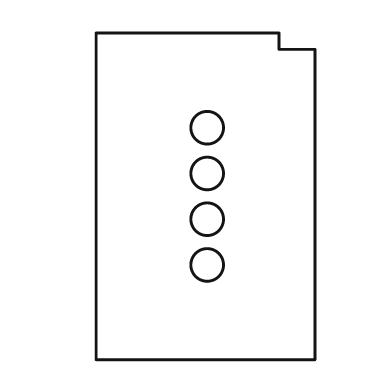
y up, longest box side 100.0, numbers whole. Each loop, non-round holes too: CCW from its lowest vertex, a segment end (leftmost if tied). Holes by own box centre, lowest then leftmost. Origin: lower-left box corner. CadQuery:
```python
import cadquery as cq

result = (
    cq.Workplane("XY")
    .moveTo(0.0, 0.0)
    .lineTo(67.0, 0.0)
    .lineTo(67.0, 95.0)
    .lineTo(56.0, 95.0)
    .lineTo(56.0, 100.0)
    .lineTo(0.0, 100.0)
    .close()
    .moveTo(34.0, 29.0)
    .circle(5.0)
    .moveTo(34.0, 43.0)
    .circle(5.0)
    .moveTo(34.0, 57.0)
    .circle(5.0)
    .moveTo(34.0, 71.0)
    .circle(5.0)
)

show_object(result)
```